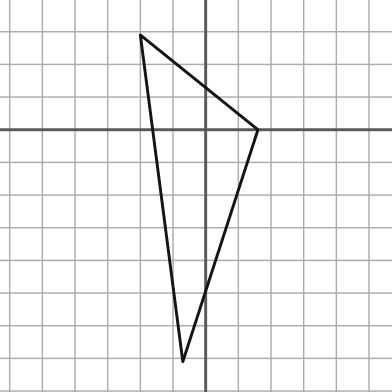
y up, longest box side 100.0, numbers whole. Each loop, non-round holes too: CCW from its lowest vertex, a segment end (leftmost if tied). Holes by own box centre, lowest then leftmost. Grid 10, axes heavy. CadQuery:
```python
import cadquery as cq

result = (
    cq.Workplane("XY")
    .moveTo(-7.0, -71.0)
    .lineTo(16.0, 0.0)
    .lineTo(-20.0, 29.0)
    .close()
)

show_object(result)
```